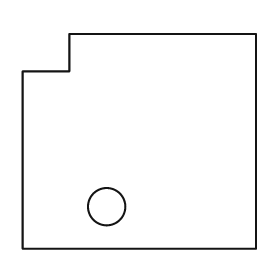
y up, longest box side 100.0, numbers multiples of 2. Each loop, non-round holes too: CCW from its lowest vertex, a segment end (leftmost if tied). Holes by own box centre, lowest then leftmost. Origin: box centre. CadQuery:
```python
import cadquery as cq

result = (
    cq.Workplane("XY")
    .moveTo(-50.0, -46.0)
    .lineTo(50.0, -46.0)
    .lineTo(50.0, 46.0)
    .lineTo(-30.0, 46.0)
    .lineTo(-30.0, 30.0)
    .lineTo(-50.0, 30.0)
    .close()
    .moveTo(-14.0, -28.0)
    .circle(8.0)
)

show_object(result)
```